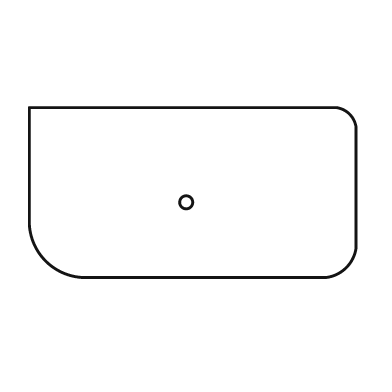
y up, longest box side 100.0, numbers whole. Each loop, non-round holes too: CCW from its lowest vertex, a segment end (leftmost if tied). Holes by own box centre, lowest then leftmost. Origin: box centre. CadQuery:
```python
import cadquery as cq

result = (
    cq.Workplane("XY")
    .moveTo(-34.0, -26.0)
    .lineTo(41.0, -26.0)
    .threePointArc((47.0, -23.0), (50.0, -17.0))
    .lineTo(50.0, 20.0)
    .threePointArc((48.0, 24.0), (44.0, 26.0))
    .lineTo(-50.0, 26.0)
    .lineTo(-50.0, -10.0)
    .threePointArc((-45.0, -21.0), (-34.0, -26.0))
    .close()
    .moveTo(-2.0, -3.0)
    .circle(2.0)
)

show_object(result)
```